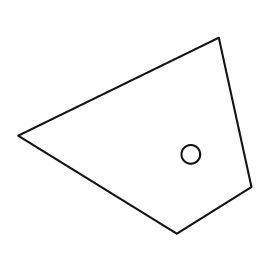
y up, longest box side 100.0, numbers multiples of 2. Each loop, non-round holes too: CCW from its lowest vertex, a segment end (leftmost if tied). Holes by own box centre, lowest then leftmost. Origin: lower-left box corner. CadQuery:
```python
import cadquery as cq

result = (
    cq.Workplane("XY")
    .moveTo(68.0, 0.0)
    .lineTo(100.0, 20.0)
    .lineTo(86.0, 84.0)
    .lineTo(0.0, 42.0)
    .close()
    .moveTo(74.0, 34.0)
    .circle(4.0)
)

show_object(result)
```